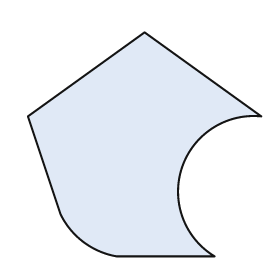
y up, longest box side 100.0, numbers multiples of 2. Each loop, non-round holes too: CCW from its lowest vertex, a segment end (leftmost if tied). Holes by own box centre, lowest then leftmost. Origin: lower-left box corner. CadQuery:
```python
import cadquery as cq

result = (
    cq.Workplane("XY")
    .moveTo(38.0, 0.0)
    .lineTo(80.0, 0.0)
    .threePointArc((66.0, 38.0), (100.0, 60.0))
    .lineTo(50.0, 96.0)
    .lineTo(0.0, 60.0)
    .lineTo(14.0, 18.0)
    .threePointArc((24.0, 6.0), (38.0, 0.0))
    .close()
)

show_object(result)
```